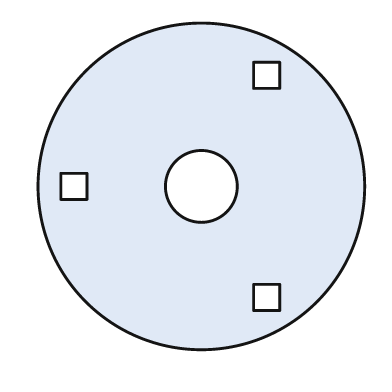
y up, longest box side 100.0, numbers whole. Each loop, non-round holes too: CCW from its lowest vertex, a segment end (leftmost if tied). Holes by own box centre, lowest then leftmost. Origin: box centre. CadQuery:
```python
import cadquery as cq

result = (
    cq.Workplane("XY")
    .moveTo(0.0, 0.0)
    .circle(50.0)
    .moveTo(16.0, -38.0)
    .lineTo(24.0, -38.0)
    .lineTo(24.0, -30.0)
    .lineTo(16.0, -30.0)
    .close()
    .moveTo(-43.0, -4.0)
    .lineTo(-35.0, -4.0)
    .lineTo(-35.0, 4.0)
    .lineTo(-43.0, 4.0)
    .close()
    .moveTo(0.0, 0.0)
    .circle(11.0)
    .moveTo(16.0, 30.0)
    .lineTo(24.0, 30.0)
    .lineTo(24.0, 38.0)
    .lineTo(16.0, 38.0)
    .close()
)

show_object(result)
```